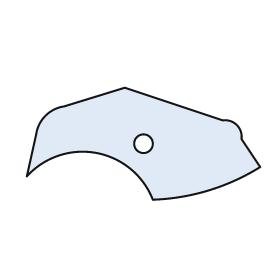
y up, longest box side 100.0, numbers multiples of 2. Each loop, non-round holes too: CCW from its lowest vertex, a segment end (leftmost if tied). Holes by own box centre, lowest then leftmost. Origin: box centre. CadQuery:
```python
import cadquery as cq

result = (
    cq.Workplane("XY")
    .moveTo(4.0, -24.0)
    .threePointArc((28.0, -20.0), (50.0, -10.0))
    .lineTo(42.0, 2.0)
    .threePointArc((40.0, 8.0), (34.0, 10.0))
    .lineTo(-8.0, 24.0)
    .lineTo(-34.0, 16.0)
    .threePointArc((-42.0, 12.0), (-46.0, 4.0))
    .lineTo(-50.0, -14.0)
    .threePointArc((-20.0, -4.0), (4.0, -24.0))
    .close()
    .moveTo(0.0, 0.0)
    .circle(4.0)
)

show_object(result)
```